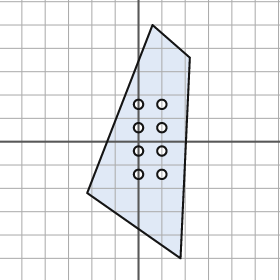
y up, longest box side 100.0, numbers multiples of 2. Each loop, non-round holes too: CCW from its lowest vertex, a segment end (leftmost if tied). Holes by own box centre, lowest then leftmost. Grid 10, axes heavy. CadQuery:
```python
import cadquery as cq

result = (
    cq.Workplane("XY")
    .moveTo(18.0, -50.0)
    .lineTo(22.0, 36.0)
    .lineTo(6.0, 50.0)
    .lineTo(-22.0, -22.0)
    .close()
    .moveTo(0.0, -14.0)
    .circle(2.0)
    .moveTo(10.0, -14.0)
    .circle(2.0)
    .moveTo(0.0, -4.0)
    .circle(2.0)
    .moveTo(10.0, -4.0)
    .circle(2.0)
    .moveTo(0.0, 6.0)
    .circle(2.0)
    .moveTo(10.0, 6.0)
    .circle(2.0)
    .moveTo(0.0, 16.0)
    .circle(2.0)
    .moveTo(10.0, 16.0)
    .circle(2.0)
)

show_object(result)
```